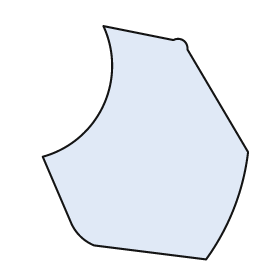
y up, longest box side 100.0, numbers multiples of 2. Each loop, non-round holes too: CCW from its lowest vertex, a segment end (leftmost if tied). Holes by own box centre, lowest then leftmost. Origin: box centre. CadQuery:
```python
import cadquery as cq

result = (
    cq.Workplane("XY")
    .moveTo(26.0, -50.0)
    .threePointArc((38.0, -28.0), (44.0, -4.0))
    .lineTo(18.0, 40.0)
    .threePointArc((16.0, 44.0), (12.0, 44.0))
    .lineTo(-18.0, 50.0)
    .threePointArc((-18.0, 16.0), (-44.0, -6.0))
    .lineTo(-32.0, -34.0)
    .threePointArc((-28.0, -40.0), (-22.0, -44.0))
    .close()
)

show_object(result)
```